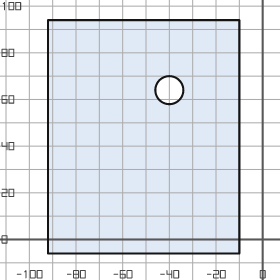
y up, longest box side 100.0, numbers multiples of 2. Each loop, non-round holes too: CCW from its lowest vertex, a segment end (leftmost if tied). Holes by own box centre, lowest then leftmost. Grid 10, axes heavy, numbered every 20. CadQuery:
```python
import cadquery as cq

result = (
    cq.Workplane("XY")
    .moveTo(-92.0, -6.0)
    .lineTo(-10.0, -6.0)
    .lineTo(-10.0, 94.0)
    .lineTo(-92.0, 94.0)
    .close()
    .moveTo(-40.0, 64.0)
    .circle(6.0)
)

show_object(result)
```